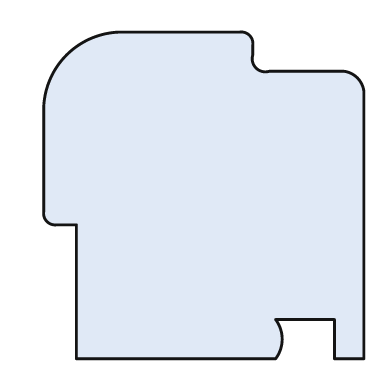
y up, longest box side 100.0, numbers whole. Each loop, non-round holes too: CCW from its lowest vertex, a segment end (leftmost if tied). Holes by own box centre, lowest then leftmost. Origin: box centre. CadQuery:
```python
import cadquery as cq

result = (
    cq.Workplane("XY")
    .moveTo(-39.0, -50.0)
    .lineTo(22.0, -50.0)
    .threePointArc((24.0, -44.0), (22.0, -38.0))
    .lineTo(40.0, -38.0)
    .lineTo(40.0, -50.0)
    .lineTo(49.0, -50.0)
    .lineTo(49.0, 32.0)
    .threePointArc((47.0, 36.0), (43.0, 38.0))
    .lineTo(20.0, 38.0)
    .threePointArc((16.0, 39.0), (15.0, 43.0))
    .lineTo(15.0, 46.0)
    .threePointArc((14.0, 49.0), (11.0, 50.0))
    .lineTo(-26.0, 50.0)
    .threePointArc((-42.0, 43.0), (-49.0, 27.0))
    .lineTo(-49.0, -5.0)
    .threePointArc((-48.0, -8.0), (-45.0, -9.0))
    .lineTo(-39.0, -9.0)
    .close()
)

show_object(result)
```